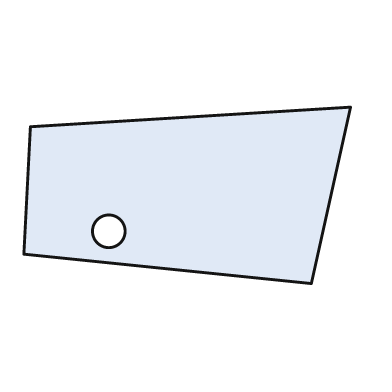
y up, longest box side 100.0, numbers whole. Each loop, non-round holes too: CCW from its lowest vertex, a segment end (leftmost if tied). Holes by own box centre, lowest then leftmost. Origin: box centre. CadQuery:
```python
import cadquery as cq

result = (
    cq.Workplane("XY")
    .moveTo(38.0, -27.0)
    .lineTo(50.0, 27.0)
    .lineTo(-48.0, 21.0)
    .lineTo(-50.0, -18.0)
    .close()
    .moveTo(-24.0, -11.0)
    .circle(5.0)
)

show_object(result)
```